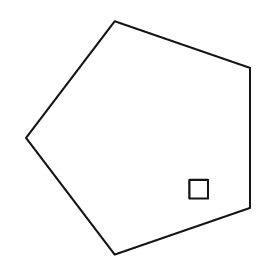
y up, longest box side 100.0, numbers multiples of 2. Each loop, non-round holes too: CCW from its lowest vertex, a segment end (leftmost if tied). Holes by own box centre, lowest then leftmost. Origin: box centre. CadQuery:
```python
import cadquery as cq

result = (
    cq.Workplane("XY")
    .moveTo(-10.0, -50.0)
    .lineTo(48.0, -30.0)
    .lineTo(48.0, 30.0)
    .lineTo(-10.0, 50.0)
    .lineTo(-48.0, 0.0)
    .close()
    .moveTo(22.0, -26.0)
    .lineTo(30.0, -26.0)
    .lineTo(30.0, -18.0)
    .lineTo(22.0, -18.0)
    .close()
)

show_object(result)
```